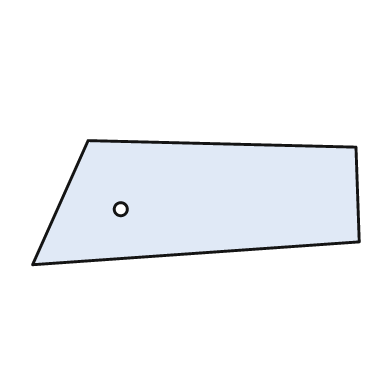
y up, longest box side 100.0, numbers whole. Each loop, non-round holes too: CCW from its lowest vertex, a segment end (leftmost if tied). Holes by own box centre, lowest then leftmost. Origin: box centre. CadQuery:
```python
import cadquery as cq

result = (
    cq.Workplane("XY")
    .moveTo(-50.0, -19.0)
    .lineTo(50.0, -12.0)
    .lineTo(49.0, 17.0)
    .lineTo(-33.0, 19.0)
    .close()
    .moveTo(-23.0, -2.0)
    .circle(2.0)
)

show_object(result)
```